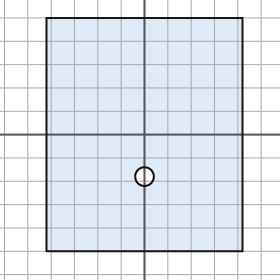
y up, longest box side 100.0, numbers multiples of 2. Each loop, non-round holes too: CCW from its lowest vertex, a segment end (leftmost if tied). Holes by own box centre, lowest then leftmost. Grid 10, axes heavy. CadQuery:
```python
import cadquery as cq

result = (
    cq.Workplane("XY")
    .moveTo(-42.0, -50.0)
    .lineTo(42.0, -50.0)
    .lineTo(42.0, 50.0)
    .lineTo(-42.0, 50.0)
    .close()
    .moveTo(0.0, -18.0)
    .circle(4.0)
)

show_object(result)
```